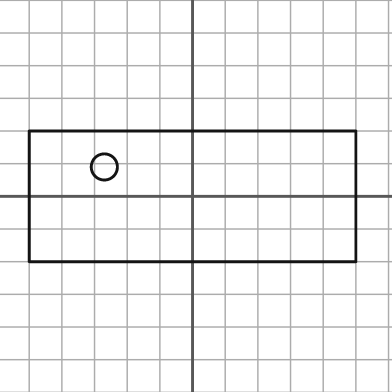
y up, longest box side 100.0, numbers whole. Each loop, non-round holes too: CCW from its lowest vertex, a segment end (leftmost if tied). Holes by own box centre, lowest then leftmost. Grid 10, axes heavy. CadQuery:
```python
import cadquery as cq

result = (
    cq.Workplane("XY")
    .moveTo(-50.0, -20.0)
    .lineTo(50.0, -20.0)
    .lineTo(50.0, 20.0)
    .lineTo(-50.0, 20.0)
    .close()
    .moveTo(-27.0, 9.0)
    .circle(4.0)
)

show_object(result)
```